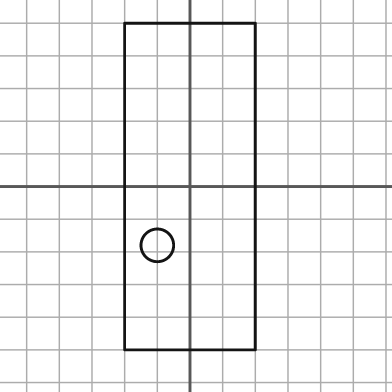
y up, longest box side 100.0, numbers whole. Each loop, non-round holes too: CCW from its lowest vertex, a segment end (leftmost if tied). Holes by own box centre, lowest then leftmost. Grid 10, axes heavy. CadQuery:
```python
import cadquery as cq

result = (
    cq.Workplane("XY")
    .moveTo(-20.0, -50.0)
    .lineTo(20.0, -50.0)
    .lineTo(20.0, 50.0)
    .lineTo(-20.0, 50.0)
    .close()
    .moveTo(-10.0, -18.0)
    .circle(5.0)
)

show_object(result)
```